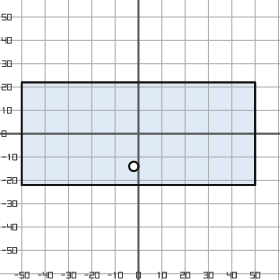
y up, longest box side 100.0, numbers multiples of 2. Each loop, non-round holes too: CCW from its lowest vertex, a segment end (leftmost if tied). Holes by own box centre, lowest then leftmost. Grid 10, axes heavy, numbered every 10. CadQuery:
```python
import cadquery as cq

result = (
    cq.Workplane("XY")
    .moveTo(-50.0, -22.0)
    .lineTo(50.0, -22.0)
    .lineTo(50.0, 22.0)
    .lineTo(-50.0, 22.0)
    .close()
    .moveTo(-2.0, -14.0)
    .circle(2.0)
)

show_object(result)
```